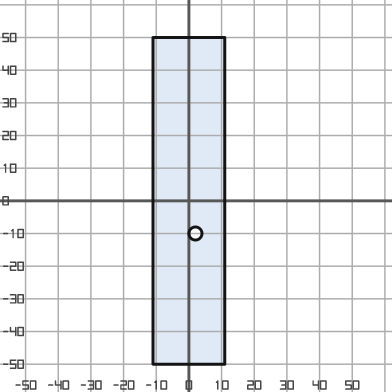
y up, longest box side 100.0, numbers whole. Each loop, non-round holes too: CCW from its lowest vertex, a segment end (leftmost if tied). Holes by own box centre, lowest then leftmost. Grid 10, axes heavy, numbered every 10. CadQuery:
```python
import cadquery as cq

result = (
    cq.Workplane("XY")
    .moveTo(-11.0, -50.0)
    .lineTo(11.0, -50.0)
    .lineTo(11.0, 50.0)
    .lineTo(-11.0, 50.0)
    .close()
    .moveTo(2.0, -10.0)
    .circle(2.0)
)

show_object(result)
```